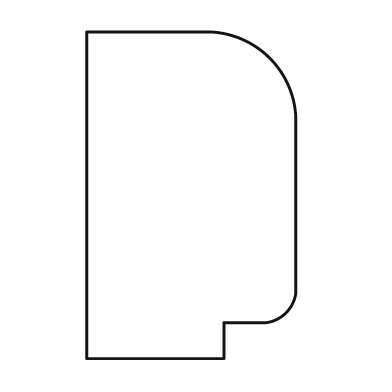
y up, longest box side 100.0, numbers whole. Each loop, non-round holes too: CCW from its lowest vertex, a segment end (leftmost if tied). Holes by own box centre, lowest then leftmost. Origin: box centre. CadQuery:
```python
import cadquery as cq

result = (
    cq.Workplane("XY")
    .moveTo(-32.0, -50.0)
    .lineTo(10.0, -50.0)
    .lineTo(10.0, -39.0)
    .lineTo(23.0, -39.0)
    .threePointArc((29.0, -36.0), (32.0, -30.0))
    .lineTo(32.0, 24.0)
    .threePointArc((24.0, 42.0), (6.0, 50.0))
    .lineTo(-32.0, 50.0)
    .close()
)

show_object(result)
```